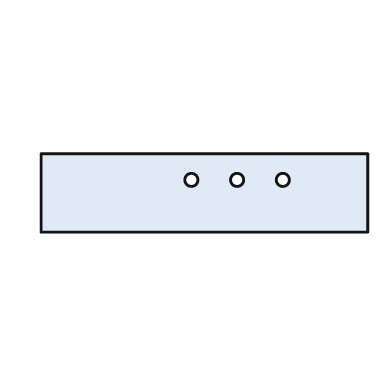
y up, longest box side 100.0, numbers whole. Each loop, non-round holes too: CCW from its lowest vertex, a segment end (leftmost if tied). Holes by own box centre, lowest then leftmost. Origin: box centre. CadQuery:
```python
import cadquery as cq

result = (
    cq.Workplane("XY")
    .moveTo(-50.0, -12.0)
    .lineTo(50.0, -12.0)
    .lineTo(50.0, 12.0)
    .lineTo(-50.0, 12.0)
    .close()
    .moveTo(-4.0, 4.0)
    .circle(2.0)
    .moveTo(10.0, 4.0)
    .circle(2.0)
    .moveTo(24.0, 4.0)
    .circle(2.0)
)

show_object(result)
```